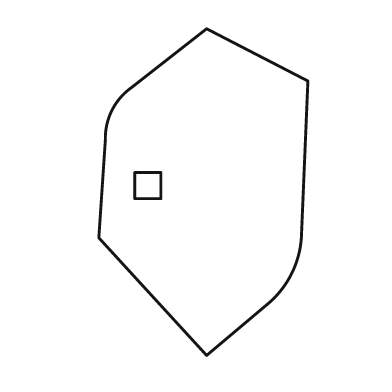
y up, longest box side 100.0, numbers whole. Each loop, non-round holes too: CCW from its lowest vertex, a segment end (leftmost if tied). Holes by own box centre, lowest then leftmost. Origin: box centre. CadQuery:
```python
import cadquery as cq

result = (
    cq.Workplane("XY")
    .moveTo(1.0, -50.0)
    .lineTo(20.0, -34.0)
    .threePointArc((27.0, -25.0), (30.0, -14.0))
    .lineTo(32.0, 34.0)
    .lineTo(1.0, 50.0)
    .lineTo(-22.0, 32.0)
    .threePointArc((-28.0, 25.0), (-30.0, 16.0))
    .lineTo(-32.0, -14.0)
    .close()
    .moveTo(-21.0, -2.0)
    .lineTo(-13.0, -2.0)
    .lineTo(-13.0, 6.0)
    .lineTo(-21.0, 6.0)
    .close()
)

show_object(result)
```